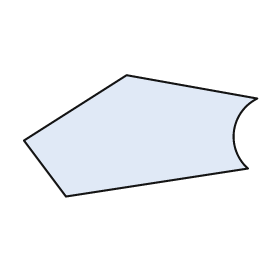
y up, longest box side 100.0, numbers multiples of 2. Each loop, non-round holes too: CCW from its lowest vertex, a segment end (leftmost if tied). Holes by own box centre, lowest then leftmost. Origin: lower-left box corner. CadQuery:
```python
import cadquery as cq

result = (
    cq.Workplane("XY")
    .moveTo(18.0, 0.0)
    .lineTo(96.0, 12.0)
    .threePointArc((90.0, 28.0), (100.0, 42.0))
    .lineTo(44.0, 52.0)
    .lineTo(0.0, 24.0)
    .close()
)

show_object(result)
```